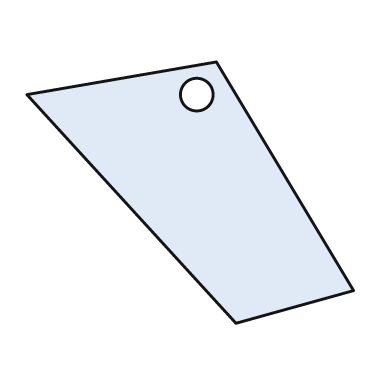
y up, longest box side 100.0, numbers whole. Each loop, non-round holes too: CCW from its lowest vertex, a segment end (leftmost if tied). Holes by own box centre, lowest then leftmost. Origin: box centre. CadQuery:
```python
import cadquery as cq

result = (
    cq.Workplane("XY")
    .moveTo(14.0, -40.0)
    .lineTo(50.0, -30.0)
    .lineTo(8.0, 40.0)
    .lineTo(-50.0, 30.0)
    .close()
    .moveTo(2.0, 30.0)
    .circle(5.0)
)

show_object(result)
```